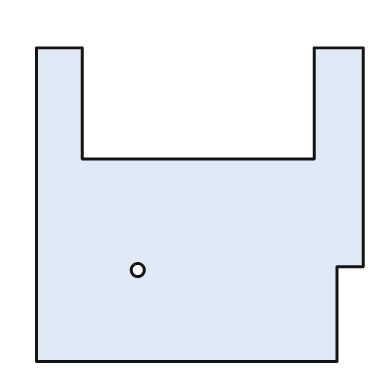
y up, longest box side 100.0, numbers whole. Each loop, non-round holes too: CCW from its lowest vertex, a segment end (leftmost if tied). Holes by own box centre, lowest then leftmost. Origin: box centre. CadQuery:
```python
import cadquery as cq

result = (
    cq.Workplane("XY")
    .moveTo(-50.0, -48.0)
    .lineTo(42.0, -48.0)
    .lineTo(42.0, -19.0)
    .lineTo(50.0, -19.0)
    .lineTo(50.0, 48.0)
    .lineTo(35.0, 48.0)
    .lineTo(35.0, 14.0)
    .lineTo(-36.0, 14.0)
    .lineTo(-36.0, 48.0)
    .lineTo(-50.0, 48.0)
    .close()
    .moveTo(-19.0, -20.0)
    .circle(2.0)
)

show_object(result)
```